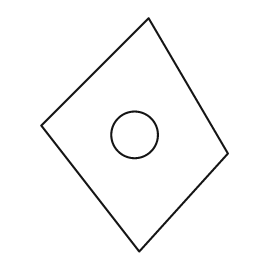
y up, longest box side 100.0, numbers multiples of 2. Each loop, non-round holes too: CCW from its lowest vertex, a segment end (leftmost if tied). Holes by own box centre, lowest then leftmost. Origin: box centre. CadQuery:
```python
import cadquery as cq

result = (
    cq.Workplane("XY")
    .moveTo(2.0, -50.0)
    .lineTo(40.0, -8.0)
    .lineTo(6.0, 50.0)
    .lineTo(-40.0, 4.0)
    .close()
    .moveTo(0.0, 0.0)
    .circle(10.0)
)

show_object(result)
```